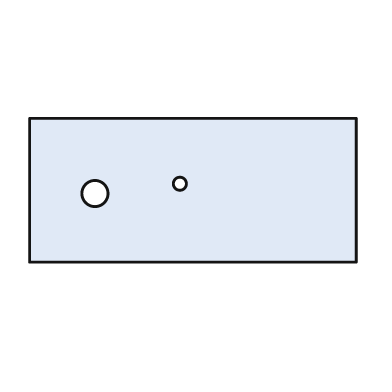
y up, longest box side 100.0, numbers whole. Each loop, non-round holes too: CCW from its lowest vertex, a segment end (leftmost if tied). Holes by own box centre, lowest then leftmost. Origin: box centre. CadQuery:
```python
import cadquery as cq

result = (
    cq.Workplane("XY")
    .moveTo(-50.0, -22.0)
    .lineTo(50.0, -22.0)
    .lineTo(50.0, 22.0)
    .lineTo(-50.0, 22.0)
    .close()
    .moveTo(-30.0, -1.0)
    .circle(4.0)
    .moveTo(-4.0, 2.0)
    .circle(2.0)
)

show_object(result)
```